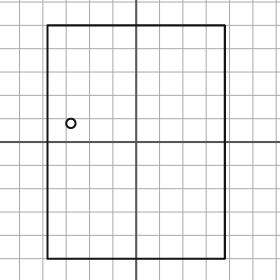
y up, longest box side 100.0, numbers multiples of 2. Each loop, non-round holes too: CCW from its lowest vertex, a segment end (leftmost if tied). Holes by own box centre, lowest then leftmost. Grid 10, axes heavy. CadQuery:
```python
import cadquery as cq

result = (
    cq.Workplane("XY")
    .moveTo(-38.0, -50.0)
    .lineTo(38.0, -50.0)
    .lineTo(38.0, 50.0)
    .lineTo(-38.0, 50.0)
    .close()
    .moveTo(-28.0, 8.0)
    .circle(2.0)
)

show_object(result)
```